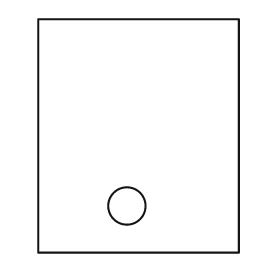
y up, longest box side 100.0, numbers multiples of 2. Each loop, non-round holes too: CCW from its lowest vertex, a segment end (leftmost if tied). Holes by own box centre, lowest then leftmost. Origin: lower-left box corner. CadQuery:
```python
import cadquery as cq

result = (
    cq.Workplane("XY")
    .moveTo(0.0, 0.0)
    .lineTo(86.0, 0.0)
    .lineTo(86.0, 100.0)
    .lineTo(0.0, 100.0)
    .close()
    .moveTo(38.0, 20.0)
    .circle(8.0)
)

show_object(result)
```